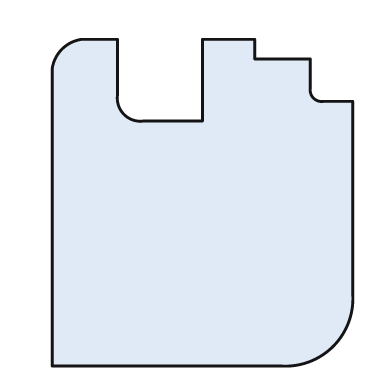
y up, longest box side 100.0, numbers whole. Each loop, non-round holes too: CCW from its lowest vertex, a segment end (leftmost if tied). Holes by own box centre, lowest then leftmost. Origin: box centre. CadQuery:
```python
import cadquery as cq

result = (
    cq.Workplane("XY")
    .moveTo(-46.0, -50.0)
    .lineTo(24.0, -50.0)
    .threePointArc((40.0, -44.0), (46.0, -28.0))
    .lineTo(46.0, 31.0)
    .lineTo(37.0, 31.0)
    .threePointArc((34.0, 32.0), (33.0, 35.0))
    .lineTo(33.0, 44.0)
    .lineTo(16.0, 44.0)
    .lineTo(16.0, 50.0)
    .lineTo(0.0, 50.0)
    .lineTo(0.0, 25.0)
    .lineTo(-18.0, 25.0)
    .threePointArc((-24.0, 27.0), (-26.0, 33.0))
    .lineTo(-26.0, 50.0)
    .lineTo(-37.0, 50.0)
    .threePointArc((-43.0, 47.0), (-46.0, 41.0))
    .close()
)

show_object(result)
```